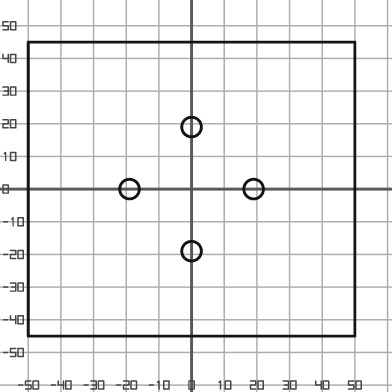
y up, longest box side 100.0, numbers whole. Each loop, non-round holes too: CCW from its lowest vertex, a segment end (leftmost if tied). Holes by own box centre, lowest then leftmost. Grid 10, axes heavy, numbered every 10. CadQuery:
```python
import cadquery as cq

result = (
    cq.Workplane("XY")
    .moveTo(-50.0, -45.0)
    .lineTo(50.0, -45.0)
    .lineTo(50.0, 45.0)
    .lineTo(-50.0, 45.0)
    .close()
    .moveTo(0.0, -19.0)
    .circle(3.0)
    .moveTo(-19.0, 0.0)
    .circle(3.0)
    .moveTo(19.0, 0.0)
    .circle(3.0)
    .moveTo(0.0, 19.0)
    .circle(3.0)
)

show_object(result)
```